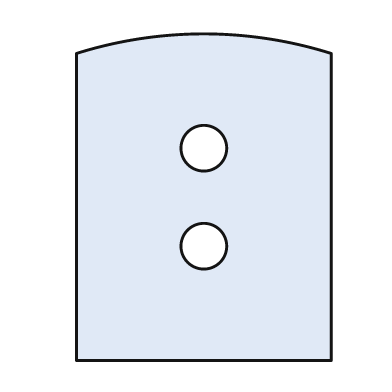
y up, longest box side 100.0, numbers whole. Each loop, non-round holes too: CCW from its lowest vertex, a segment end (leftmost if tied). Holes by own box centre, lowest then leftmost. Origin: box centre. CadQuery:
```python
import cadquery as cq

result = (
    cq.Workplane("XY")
    .moveTo(-39.0, -50.0)
    .lineTo(39.0, -50.0)
    .lineTo(39.0, 44.0)
    .threePointArc((0.0, 50.0), (-39.0, 44.0))
    .close()
    .moveTo(0.0, -15.0)
    .circle(7.0)
    .moveTo(0.0, 15.0)
    .circle(7.0)
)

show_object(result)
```